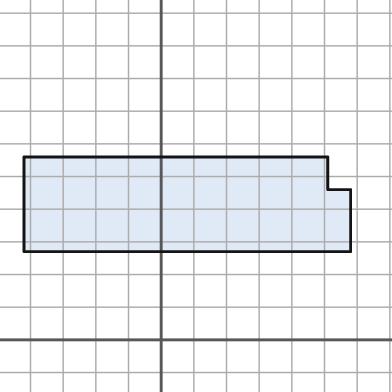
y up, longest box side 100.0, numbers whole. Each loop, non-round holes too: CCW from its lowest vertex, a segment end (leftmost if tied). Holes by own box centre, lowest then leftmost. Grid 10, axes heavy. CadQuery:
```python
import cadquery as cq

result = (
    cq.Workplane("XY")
    .moveTo(-42.0, 27.0)
    .lineTo(58.0, 27.0)
    .lineTo(58.0, 46.0)
    .lineTo(51.0, 46.0)
    .lineTo(51.0, 56.0)
    .lineTo(-42.0, 56.0)
    .close()
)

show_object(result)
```